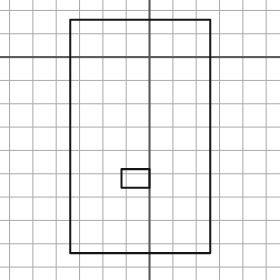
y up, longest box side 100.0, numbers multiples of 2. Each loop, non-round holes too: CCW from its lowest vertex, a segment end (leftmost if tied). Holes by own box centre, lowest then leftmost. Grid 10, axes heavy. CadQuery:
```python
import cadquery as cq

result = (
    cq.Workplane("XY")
    .moveTo(-34.0, -84.0)
    .lineTo(26.0, -84.0)
    .lineTo(26.0, 16.0)
    .lineTo(-34.0, 16.0)
    .close()
    .moveTo(-12.0, -56.0)
    .lineTo(0.0, -56.0)
    .lineTo(0.0, -48.0)
    .lineTo(-12.0, -48.0)
    .close()
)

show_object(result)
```